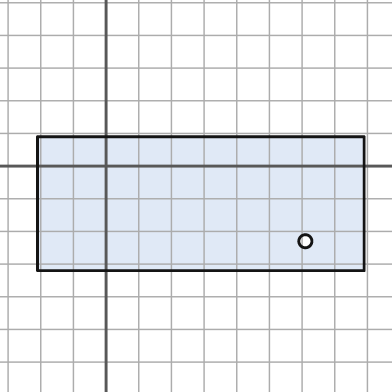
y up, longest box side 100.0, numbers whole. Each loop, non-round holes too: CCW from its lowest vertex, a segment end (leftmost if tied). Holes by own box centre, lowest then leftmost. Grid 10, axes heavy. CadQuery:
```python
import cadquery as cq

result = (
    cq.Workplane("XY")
    .moveTo(-21.0, -32.0)
    .lineTo(79.0, -32.0)
    .lineTo(79.0, 9.0)
    .lineTo(-21.0, 9.0)
    .close()
    .moveTo(61.0, -23.0)
    .circle(2.0)
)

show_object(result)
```